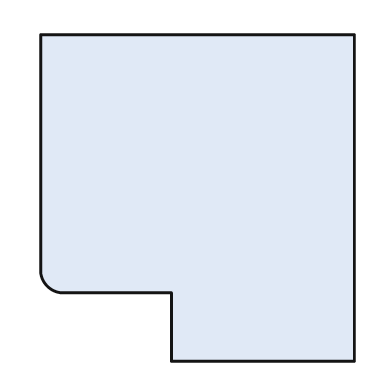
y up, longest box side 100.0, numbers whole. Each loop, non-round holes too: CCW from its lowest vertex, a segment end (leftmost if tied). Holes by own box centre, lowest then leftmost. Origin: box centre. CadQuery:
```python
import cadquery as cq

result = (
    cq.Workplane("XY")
    .moveTo(-8.0, -50.0)
    .lineTo(48.0, -50.0)
    .lineTo(48.0, 50.0)
    .lineTo(-48.0, 50.0)
    .lineTo(-48.0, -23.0)
    .threePointArc((-46.0, -27.0), (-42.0, -29.0))
    .lineTo(-8.0, -29.0)
    .close()
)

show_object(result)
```